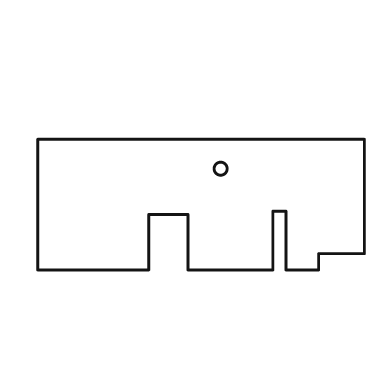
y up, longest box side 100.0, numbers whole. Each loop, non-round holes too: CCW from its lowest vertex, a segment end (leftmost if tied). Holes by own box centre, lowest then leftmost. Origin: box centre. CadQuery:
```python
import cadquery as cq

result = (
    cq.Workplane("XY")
    .moveTo(-50.0, -20.0)
    .lineTo(-16.0, -20.0)
    .lineTo(-16.0, -3.0)
    .lineTo(-4.0, -3.0)
    .lineTo(-4.0, -20.0)
    .lineTo(22.0, -20.0)
    .lineTo(22.0, -2.0)
    .lineTo(26.0, -2.0)
    .lineTo(26.0, -20.0)
    .lineTo(36.0, -20.0)
    .lineTo(36.0, -15.0)
    .lineTo(50.0, -15.0)
    .lineTo(50.0, 20.0)
    .lineTo(-50.0, 20.0)
    .close()
    .moveTo(6.0, 11.0)
    .circle(2.0)
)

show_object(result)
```